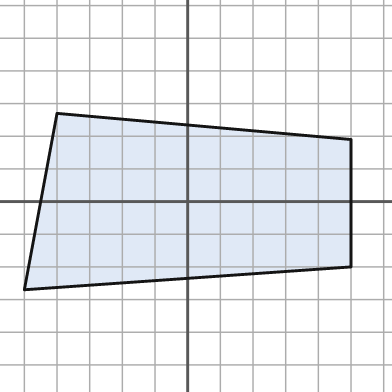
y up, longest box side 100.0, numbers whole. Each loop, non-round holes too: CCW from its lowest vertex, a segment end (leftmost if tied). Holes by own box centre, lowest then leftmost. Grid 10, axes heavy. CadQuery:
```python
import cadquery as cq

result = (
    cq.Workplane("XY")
    .moveTo(-50.0, -27.0)
    .lineTo(50.0, -20.0)
    .lineTo(50.0, 19.0)
    .lineTo(-40.0, 27.0)
    .close()
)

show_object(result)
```